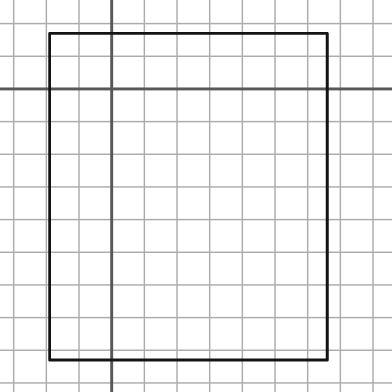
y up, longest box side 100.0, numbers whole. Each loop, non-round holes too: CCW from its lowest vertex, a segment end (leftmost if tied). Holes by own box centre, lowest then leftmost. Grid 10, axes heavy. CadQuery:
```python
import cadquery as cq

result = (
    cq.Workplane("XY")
    .moveTo(-19.0, -83.0)
    .lineTo(66.0, -83.0)
    .lineTo(66.0, 17.0)
    .lineTo(-19.0, 17.0)
    .close()
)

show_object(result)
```